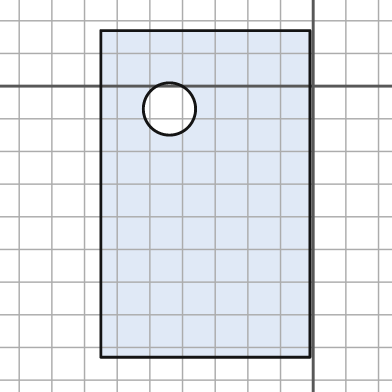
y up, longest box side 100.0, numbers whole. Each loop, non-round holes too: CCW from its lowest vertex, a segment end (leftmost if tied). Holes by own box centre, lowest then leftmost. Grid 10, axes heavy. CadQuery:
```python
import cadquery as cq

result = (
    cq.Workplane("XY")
    .moveTo(-65.0, -83.0)
    .lineTo(-1.0, -83.0)
    .lineTo(-1.0, 17.0)
    .lineTo(-65.0, 17.0)
    .close()
    .moveTo(-44.0, -7.0)
    .circle(8.0)
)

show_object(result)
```